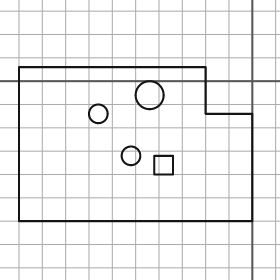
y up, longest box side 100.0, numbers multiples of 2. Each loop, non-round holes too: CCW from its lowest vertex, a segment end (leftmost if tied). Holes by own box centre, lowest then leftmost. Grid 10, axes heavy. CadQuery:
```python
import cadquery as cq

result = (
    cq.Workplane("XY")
    .moveTo(-100.0, -60.0)
    .lineTo(0.0, -60.0)
    .lineTo(0.0, -14.0)
    .lineTo(-20.0, -14.0)
    .lineTo(-20.0, 6.0)
    .lineTo(-100.0, 6.0)
    .close()
    .moveTo(-42.0, -40.0)
    .lineTo(-34.0, -40.0)
    .lineTo(-34.0, -32.0)
    .lineTo(-42.0, -32.0)
    .close()
    .moveTo(-52.0, -32.0)
    .circle(4.0)
    .moveTo(-66.0, -14.0)
    .circle(4.0)
    .moveTo(-44.0, -6.0)
    .circle(6.0)
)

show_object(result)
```